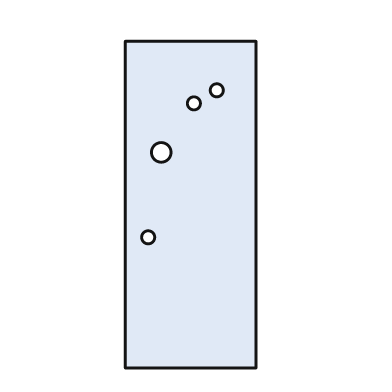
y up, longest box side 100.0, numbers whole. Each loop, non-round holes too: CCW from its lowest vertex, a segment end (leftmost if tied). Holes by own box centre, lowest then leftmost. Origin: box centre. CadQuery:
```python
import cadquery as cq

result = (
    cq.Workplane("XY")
    .moveTo(-20.0, -50.0)
    .lineTo(20.0, -50.0)
    .lineTo(20.0, 50.0)
    .lineTo(-20.0, 50.0)
    .close()
    .moveTo(-13.0, -10.0)
    .circle(2.0)
    .moveTo(-9.0, 16.0)
    .circle(3.0)
    .moveTo(1.0, 31.0)
    .circle(2.0)
    .moveTo(8.0, 35.0)
    .circle(2.0)
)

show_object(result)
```